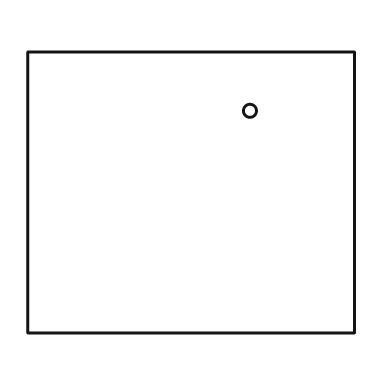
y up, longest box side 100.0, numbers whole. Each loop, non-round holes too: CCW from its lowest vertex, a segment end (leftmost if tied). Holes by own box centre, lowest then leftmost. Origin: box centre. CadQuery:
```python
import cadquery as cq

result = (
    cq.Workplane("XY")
    .moveTo(-50.0, -43.0)
    .lineTo(50.0, -43.0)
    .lineTo(50.0, 43.0)
    .lineTo(-50.0, 43.0)
    .close()
    .moveTo(18.0, 25.0)
    .circle(2.0)
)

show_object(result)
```